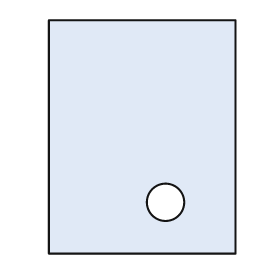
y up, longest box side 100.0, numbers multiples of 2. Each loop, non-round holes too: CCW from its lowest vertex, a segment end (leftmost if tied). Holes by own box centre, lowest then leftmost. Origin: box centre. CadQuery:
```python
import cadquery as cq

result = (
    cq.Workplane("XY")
    .moveTo(-40.0, -50.0)
    .lineTo(40.0, -50.0)
    .lineTo(40.0, 50.0)
    .lineTo(-40.0, 50.0)
    .close()
    .moveTo(10.0, -28.0)
    .circle(8.0)
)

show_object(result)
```